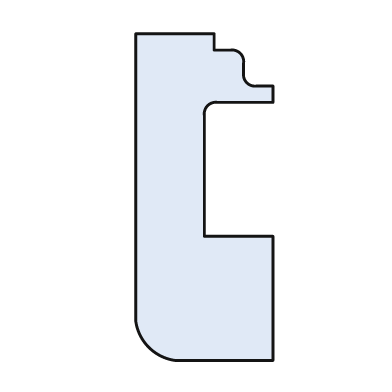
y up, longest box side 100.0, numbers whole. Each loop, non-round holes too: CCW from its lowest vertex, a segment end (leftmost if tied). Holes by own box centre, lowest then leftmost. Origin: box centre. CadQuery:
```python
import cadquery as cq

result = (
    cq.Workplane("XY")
    .moveTo(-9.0, -50.0)
    .lineTo(21.0, -50.0)
    .lineTo(21.0, -12.0)
    .lineTo(0.0, -12.0)
    .lineTo(0.0, 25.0)
    .threePointArc((1.0, 28.0), (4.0, 29.0))
    .lineTo(21.0, 29.0)
    .lineTo(21.0, 34.0)
    .lineTo(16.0, 34.0)
    .threePointArc((13.0, 35.0), (12.0, 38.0))
    .lineTo(12.0, 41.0)
    .threePointArc((11.0, 44.0), (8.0, 45.0))
    .lineTo(3.0, 45.0)
    .lineTo(3.0, 50.0)
    .lineTo(-21.0, 50.0)
    .lineTo(-21.0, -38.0)
    .threePointArc((-17.0, -46.0), (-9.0, -50.0))
    .close()
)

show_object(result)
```